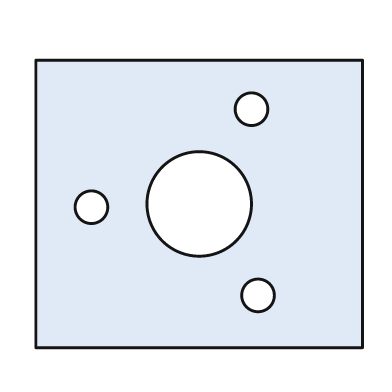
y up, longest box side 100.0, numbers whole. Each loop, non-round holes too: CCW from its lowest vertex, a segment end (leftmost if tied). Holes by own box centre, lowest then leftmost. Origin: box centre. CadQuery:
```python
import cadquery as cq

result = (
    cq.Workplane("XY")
    .moveTo(-50.0, -44.0)
    .lineTo(50.0, -44.0)
    .lineTo(50.0, 44.0)
    .lineTo(-50.0, 44.0)
    .close()
    .moveTo(18.0, -28.0)
    .circle(5.0)
    .moveTo(-33.0, -1.0)
    .circle(5.0)
    .moveTo(0.0, 0.0)
    .circle(16.0)
    .moveTo(16.0, 29.0)
    .circle(5.0)
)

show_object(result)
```